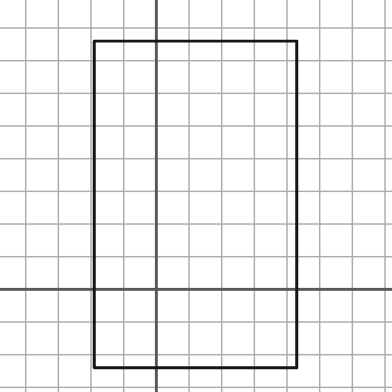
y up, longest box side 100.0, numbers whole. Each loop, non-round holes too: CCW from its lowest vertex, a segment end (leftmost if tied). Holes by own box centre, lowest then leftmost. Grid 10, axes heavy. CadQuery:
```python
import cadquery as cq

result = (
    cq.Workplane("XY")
    .moveTo(-19.0, -24.0)
    .lineTo(43.0, -24.0)
    .lineTo(43.0, 76.0)
    .lineTo(-19.0, 76.0)
    .close()
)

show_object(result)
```